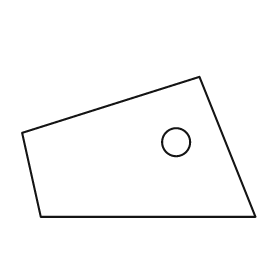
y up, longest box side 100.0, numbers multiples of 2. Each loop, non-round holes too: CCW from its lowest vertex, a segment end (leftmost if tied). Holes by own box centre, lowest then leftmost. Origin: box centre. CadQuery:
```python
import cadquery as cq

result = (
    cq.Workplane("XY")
    .moveTo(-42.0, -30.0)
    .lineTo(50.0, -30.0)
    .lineTo(26.0, 30.0)
    .lineTo(-50.0, 6.0)
    .close()
    .moveTo(16.0, 2.0)
    .circle(6.0)
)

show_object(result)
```